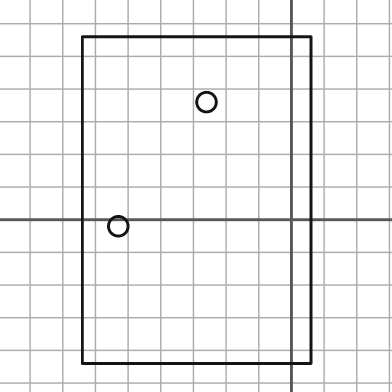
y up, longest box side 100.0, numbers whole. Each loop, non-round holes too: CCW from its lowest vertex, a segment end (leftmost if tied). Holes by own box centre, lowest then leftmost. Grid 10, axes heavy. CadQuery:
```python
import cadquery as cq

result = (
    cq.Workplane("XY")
    .moveTo(-64.0, -44.0)
    .lineTo(6.0, -44.0)
    .lineTo(6.0, 56.0)
    .lineTo(-64.0, 56.0)
    .close()
    .moveTo(-53.0, -2.0)
    .circle(3.0)
    .moveTo(-26.0, 36.0)
    .circle(3.0)
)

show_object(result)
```